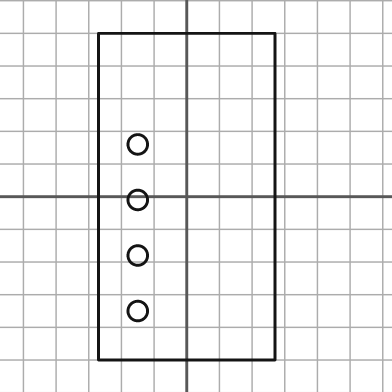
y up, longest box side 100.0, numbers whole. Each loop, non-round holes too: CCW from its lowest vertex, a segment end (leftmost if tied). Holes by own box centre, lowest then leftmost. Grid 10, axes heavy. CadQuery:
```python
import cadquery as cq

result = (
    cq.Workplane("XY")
    .moveTo(-27.0, -50.0)
    .lineTo(27.0, -50.0)
    .lineTo(27.0, 50.0)
    .lineTo(-27.0, 50.0)
    .close()
    .moveTo(-15.0, -35.0)
    .circle(3.0)
    .moveTo(-15.0, -18.0)
    .circle(3.0)
    .moveTo(-15.0, -1.0)
    .circle(3.0)
    .moveTo(-15.0, 16.0)
    .circle(3.0)
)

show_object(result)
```